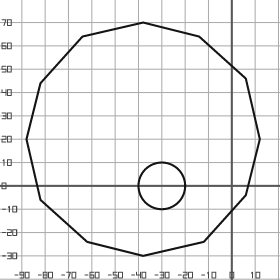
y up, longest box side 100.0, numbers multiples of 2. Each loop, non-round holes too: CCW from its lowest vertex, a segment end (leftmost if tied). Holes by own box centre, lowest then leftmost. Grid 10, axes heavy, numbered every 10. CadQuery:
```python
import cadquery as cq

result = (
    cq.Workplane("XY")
    .moveTo(-38.0, -30.0)
    .lineTo(-12.0, -24.0)
    .lineTo(6.0, -4.0)
    .lineTo(12.0, 20.0)
    .lineTo(6.0, 46.0)
    .lineTo(-14.0, 64.0)
    .lineTo(-38.0, 70.0)
    .lineTo(-64.0, 64.0)
    .lineTo(-82.0, 44.0)
    .lineTo(-88.0, 20.0)
    .lineTo(-82.0, -6.0)
    .lineTo(-62.0, -24.0)
    .close()
    .moveTo(-30.0, 0.0)
    .circle(10.0)
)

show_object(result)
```